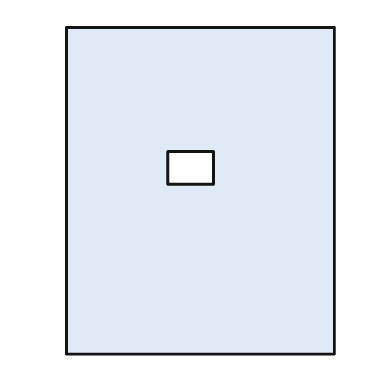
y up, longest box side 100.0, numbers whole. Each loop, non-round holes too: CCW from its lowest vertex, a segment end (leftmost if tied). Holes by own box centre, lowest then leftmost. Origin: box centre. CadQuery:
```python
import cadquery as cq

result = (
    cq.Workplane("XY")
    .moveTo(-41.0, -50.0)
    .lineTo(41.0, -50.0)
    .lineTo(41.0, 50.0)
    .lineTo(-41.0, 50.0)
    .close()
    .moveTo(-10.0, 2.0)
    .lineTo(4.0, 2.0)
    .lineTo(4.0, 12.0)
    .lineTo(-10.0, 12.0)
    .close()
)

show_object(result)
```